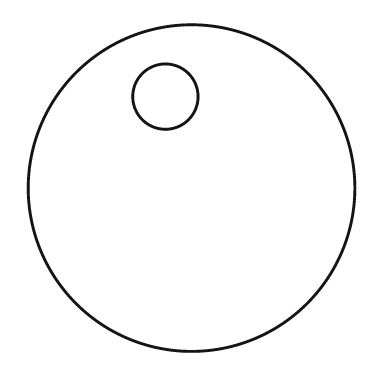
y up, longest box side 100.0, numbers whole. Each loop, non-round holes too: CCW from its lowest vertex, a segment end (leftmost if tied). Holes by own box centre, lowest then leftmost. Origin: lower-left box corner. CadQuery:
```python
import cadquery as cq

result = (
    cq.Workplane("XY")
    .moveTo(50.0, 50.0)
    .circle(50.0)
    .moveTo(42.0, 78.0)
    .circle(10.0)
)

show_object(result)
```